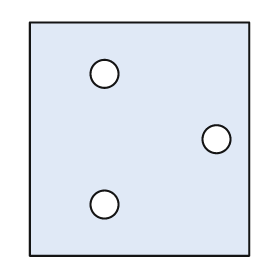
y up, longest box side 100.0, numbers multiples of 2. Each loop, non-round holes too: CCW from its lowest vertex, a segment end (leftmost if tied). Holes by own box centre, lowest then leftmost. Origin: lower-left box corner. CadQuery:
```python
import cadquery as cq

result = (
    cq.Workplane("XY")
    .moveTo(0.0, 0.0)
    .lineTo(94.0, 0.0)
    .lineTo(94.0, 100.0)
    .lineTo(0.0, 100.0)
    .close()
    .moveTo(32.0, 22.0)
    .circle(6.0)
    .moveTo(80.0, 50.0)
    .circle(6.0)
    .moveTo(32.0, 78.0)
    .circle(6.0)
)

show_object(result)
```